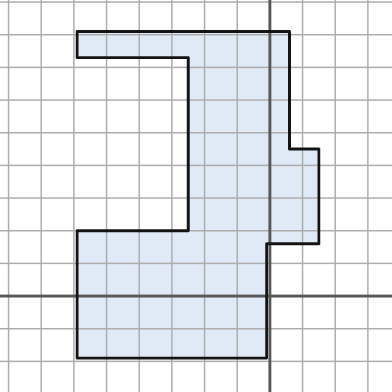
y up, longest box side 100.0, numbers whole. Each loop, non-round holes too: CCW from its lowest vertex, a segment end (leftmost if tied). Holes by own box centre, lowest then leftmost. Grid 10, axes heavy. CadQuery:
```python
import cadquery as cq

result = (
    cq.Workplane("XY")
    .moveTo(-59.0, -19.0)
    .lineTo(-1.0, -19.0)
    .lineTo(-1.0, 16.0)
    .lineTo(15.0, 16.0)
    .lineTo(15.0, 45.0)
    .lineTo(6.0, 45.0)
    .lineTo(6.0, 81.0)
    .lineTo(-59.0, 81.0)
    .lineTo(-59.0, 73.0)
    .lineTo(-25.0, 73.0)
    .lineTo(-25.0, 20.0)
    .lineTo(-59.0, 20.0)
    .close()
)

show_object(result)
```